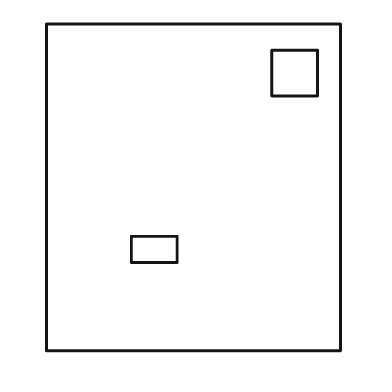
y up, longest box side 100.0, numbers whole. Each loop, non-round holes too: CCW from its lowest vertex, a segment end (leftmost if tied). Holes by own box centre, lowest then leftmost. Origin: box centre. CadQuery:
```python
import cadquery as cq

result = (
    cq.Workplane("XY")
    .moveTo(-45.0, -50.0)
    .lineTo(45.0, -50.0)
    .lineTo(45.0, 50.0)
    .lineTo(-45.0, 50.0)
    .close()
    .moveTo(-19.0, -23.0)
    .lineTo(-5.0, -23.0)
    .lineTo(-5.0, -15.0)
    .lineTo(-19.0, -15.0)
    .close()
    .moveTo(24.0, 28.0)
    .lineTo(38.0, 28.0)
    .lineTo(38.0, 42.0)
    .lineTo(24.0, 42.0)
    .close()
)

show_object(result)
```